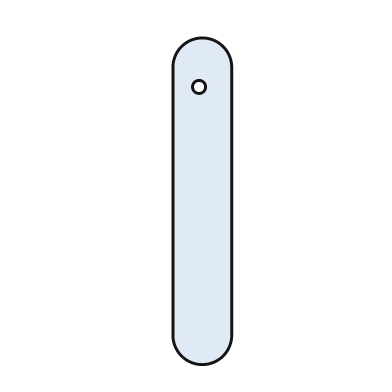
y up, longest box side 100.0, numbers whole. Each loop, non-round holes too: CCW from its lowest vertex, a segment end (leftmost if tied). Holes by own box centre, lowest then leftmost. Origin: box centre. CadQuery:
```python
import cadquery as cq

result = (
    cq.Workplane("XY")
    .moveTo(-9.0, -41.0)
    .threePointArc((0.0, -50.0), (9.0, -41.0))
    .lineTo(9.0, 41.0)
    .threePointArc((0.0, 50.0), (-9.0, 41.0))
    .close()
    .moveTo(-1.0, 35.0)
    .circle(2.0)
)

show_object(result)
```